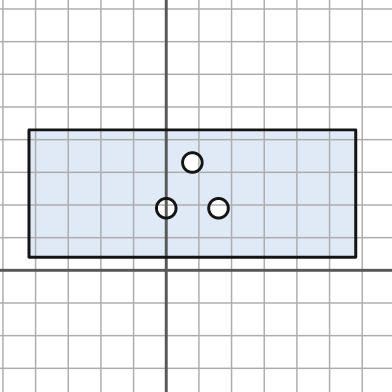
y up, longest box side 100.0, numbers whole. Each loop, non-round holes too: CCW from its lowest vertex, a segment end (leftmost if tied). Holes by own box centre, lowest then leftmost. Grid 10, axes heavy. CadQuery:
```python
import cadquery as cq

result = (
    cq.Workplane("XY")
    .moveTo(-42.0, 4.0)
    .lineTo(58.0, 4.0)
    .lineTo(58.0, 43.0)
    .lineTo(-42.0, 43.0)
    .close()
    .moveTo(0.0, 19.0)
    .circle(3.0)
    .moveTo(16.0, 19.0)
    .circle(3.0)
    .moveTo(8.0, 33.0)
    .circle(3.0)
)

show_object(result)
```